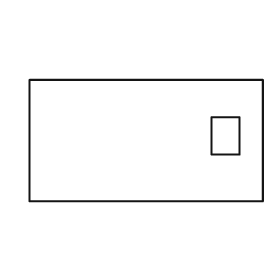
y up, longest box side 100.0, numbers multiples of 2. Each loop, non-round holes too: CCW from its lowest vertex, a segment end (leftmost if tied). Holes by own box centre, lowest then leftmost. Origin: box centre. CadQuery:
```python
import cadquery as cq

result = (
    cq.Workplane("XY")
    .moveTo(-50.0, -26.0)
    .lineTo(50.0, -26.0)
    .lineTo(50.0, 26.0)
    .lineTo(-50.0, 26.0)
    .close()
    .moveTo(28.0, -6.0)
    .lineTo(40.0, -6.0)
    .lineTo(40.0, 10.0)
    .lineTo(28.0, 10.0)
    .close()
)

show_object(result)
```